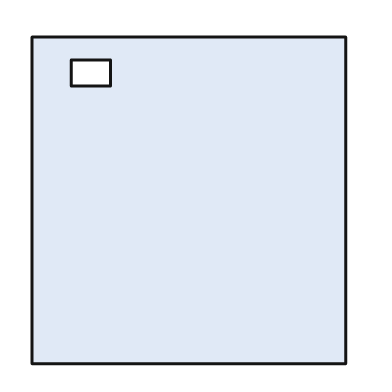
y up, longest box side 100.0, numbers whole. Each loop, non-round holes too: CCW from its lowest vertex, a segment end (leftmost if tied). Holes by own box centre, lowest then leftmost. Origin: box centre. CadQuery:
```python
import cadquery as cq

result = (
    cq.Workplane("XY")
    .moveTo(-48.0, -50.0)
    .lineTo(48.0, -50.0)
    .lineTo(48.0, 50.0)
    .lineTo(-48.0, 50.0)
    .close()
    .moveTo(-36.0, 35.0)
    .lineTo(-24.0, 35.0)
    .lineTo(-24.0, 43.0)
    .lineTo(-36.0, 43.0)
    .close()
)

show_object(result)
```